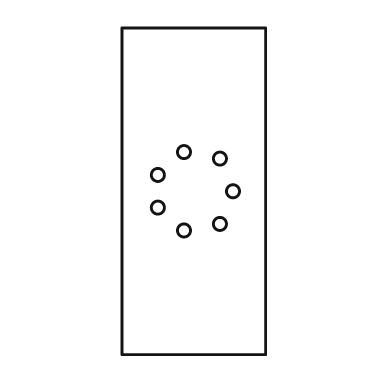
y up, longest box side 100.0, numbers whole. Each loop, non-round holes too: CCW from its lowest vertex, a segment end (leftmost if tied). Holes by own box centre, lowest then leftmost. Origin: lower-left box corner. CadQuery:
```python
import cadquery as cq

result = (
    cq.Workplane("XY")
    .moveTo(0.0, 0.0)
    .lineTo(44.0, 0.0)
    .lineTo(44.0, 100.0)
    .lineTo(0.0, 100.0)
    .close()
    .moveTo(19.0, 38.0)
    .circle(2.0)
    .moveTo(30.0, 40.0)
    .circle(2.0)
    .moveTo(11.0, 45.0)
    .circle(2.0)
    .moveTo(34.0, 50.0)
    .circle(2.0)
    .moveTo(11.0, 55.0)
    .circle(2.0)
    .moveTo(30.0, 60.0)
    .circle(2.0)
    .moveTo(19.0, 62.0)
    .circle(2.0)
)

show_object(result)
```